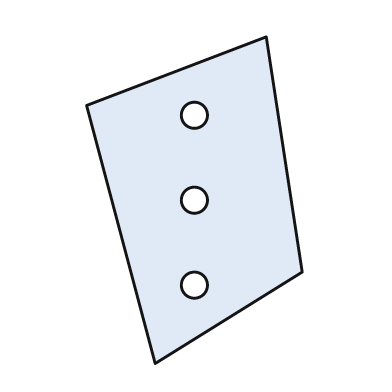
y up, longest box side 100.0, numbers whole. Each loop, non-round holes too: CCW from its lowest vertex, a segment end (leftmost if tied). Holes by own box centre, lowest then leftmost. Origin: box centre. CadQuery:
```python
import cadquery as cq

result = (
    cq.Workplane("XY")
    .moveTo(-12.0, -50.0)
    .lineTo(33.0, -22.0)
    .lineTo(22.0, 50.0)
    .lineTo(-33.0, 29.0)
    .close()
    .moveTo(0.0, -26.0)
    .circle(4.0)
    .moveTo(0.0, 0.0)
    .circle(4.0)
    .moveTo(0.0, 26.0)
    .circle(4.0)
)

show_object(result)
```